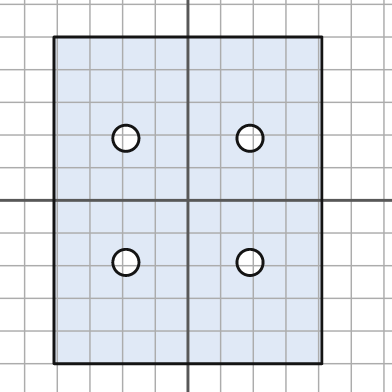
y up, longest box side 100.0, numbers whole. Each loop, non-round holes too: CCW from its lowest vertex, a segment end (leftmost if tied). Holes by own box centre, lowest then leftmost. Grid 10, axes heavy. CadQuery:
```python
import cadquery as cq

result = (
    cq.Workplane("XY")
    .moveTo(-41.0, -50.0)
    .lineTo(41.0, -50.0)
    .lineTo(41.0, 50.0)
    .lineTo(-41.0, 50.0)
    .close()
    .moveTo(-19.0, -19.0)
    .circle(4.0)
    .moveTo(19.0, -19.0)
    .circle(4.0)
    .moveTo(-19.0, 19.0)
    .circle(4.0)
    .moveTo(19.0, 19.0)
    .circle(4.0)
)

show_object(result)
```